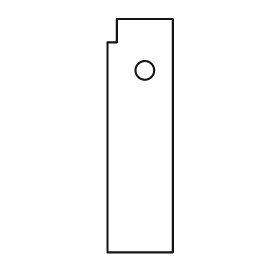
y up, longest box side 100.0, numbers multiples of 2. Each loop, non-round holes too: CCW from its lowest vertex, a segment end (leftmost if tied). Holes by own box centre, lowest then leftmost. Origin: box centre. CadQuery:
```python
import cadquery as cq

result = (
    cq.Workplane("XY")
    .moveTo(-14.0, -50.0)
    .lineTo(14.0, -50.0)
    .lineTo(14.0, 50.0)
    .lineTo(-10.0, 50.0)
    .lineTo(-10.0, 40.0)
    .lineTo(-14.0, 40.0)
    .close()
    .moveTo(2.0, 28.0)
    .circle(4.0)
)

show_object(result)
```